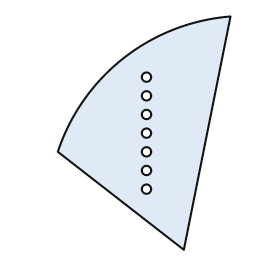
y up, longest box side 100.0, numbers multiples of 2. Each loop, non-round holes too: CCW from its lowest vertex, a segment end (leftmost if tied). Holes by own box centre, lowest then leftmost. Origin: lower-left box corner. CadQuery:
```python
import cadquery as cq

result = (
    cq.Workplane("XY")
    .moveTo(54.0, 0.0)
    .lineTo(74.0, 100.0)
    .threePointArc((28.0, 82.0), (0.0, 42.0))
    .close()
    .moveTo(38.0, 26.0)
    .circle(2.0)
    .moveTo(38.0, 34.0)
    .circle(2.0)
    .moveTo(38.0, 42.0)
    .circle(2.0)
    .moveTo(38.0, 50.0)
    .circle(2.0)
    .moveTo(38.0, 58.0)
    .circle(2.0)
    .moveTo(38.0, 66.0)
    .circle(2.0)
    .moveTo(38.0, 74.0)
    .circle(2.0)
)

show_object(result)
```